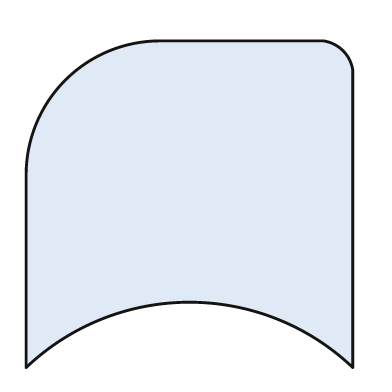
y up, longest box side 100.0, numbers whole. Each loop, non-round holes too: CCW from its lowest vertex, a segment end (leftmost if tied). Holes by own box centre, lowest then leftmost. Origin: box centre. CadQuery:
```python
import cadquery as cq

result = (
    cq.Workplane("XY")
    .moveTo(-50.0, -50.0)
    .threePointArc((0.0, -30.0), (50.0, -50.0))
    .lineTo(50.0, 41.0)
    .threePointArc((47.0, 47.0), (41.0, 50.0))
    .lineTo(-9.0, 50.0)
    .threePointArc((-38.0, 38.0), (-50.0, 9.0))
    .close()
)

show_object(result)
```